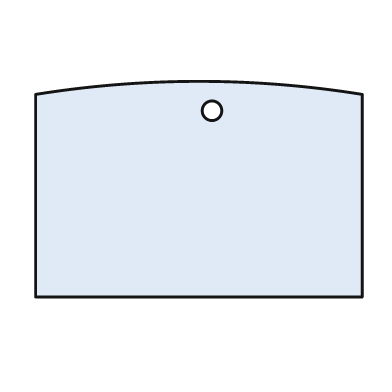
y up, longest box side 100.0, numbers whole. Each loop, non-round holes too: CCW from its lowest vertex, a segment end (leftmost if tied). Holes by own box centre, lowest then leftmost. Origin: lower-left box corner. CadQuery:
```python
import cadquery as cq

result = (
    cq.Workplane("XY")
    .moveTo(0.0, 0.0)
    .lineTo(100.0, 0.0)
    .lineTo(100.0, 62.0)
    .threePointArc((50.0, 66.0), (0.0, 62.0))
    .close()
    .moveTo(54.0, 57.0)
    .circle(3.0)
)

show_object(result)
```